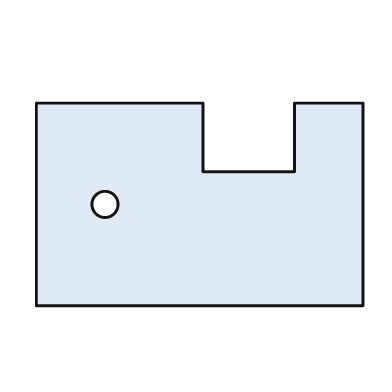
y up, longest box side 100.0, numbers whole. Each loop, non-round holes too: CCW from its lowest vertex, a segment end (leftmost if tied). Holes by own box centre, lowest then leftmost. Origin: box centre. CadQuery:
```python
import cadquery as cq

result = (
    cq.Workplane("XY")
    .moveTo(-50.0, -31.0)
    .lineTo(50.0, -31.0)
    .lineTo(50.0, 31.0)
    .lineTo(29.0, 31.0)
    .lineTo(29.0, 10.0)
    .lineTo(1.0, 10.0)
    .lineTo(1.0, 31.0)
    .lineTo(-50.0, 31.0)
    .close()
    .moveTo(-29.0, 0.0)
    .circle(4.0)
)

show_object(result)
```